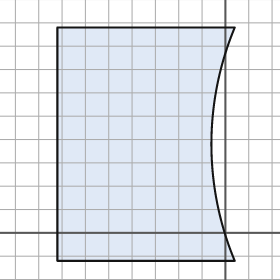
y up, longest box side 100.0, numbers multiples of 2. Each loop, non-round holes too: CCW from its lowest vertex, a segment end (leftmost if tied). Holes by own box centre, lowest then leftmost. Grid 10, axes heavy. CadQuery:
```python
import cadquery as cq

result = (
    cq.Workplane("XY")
    .moveTo(-72.0, -12.0)
    .lineTo(4.0, -12.0)
    .threePointArc((-6.0, 38.0), (4.0, 88.0))
    .lineTo(-72.0, 88.0)
    .close()
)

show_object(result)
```